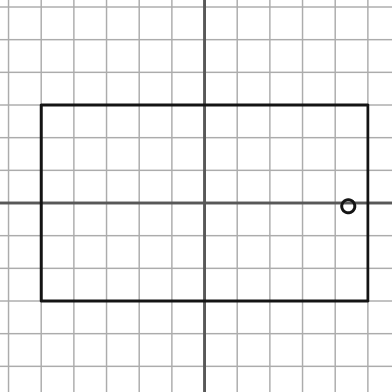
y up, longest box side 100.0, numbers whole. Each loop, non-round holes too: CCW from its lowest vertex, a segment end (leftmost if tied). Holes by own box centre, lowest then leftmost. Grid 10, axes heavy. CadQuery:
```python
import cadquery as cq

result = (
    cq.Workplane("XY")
    .moveTo(-50.0, -30.0)
    .lineTo(50.0, -30.0)
    .lineTo(50.0, 30.0)
    .lineTo(-50.0, 30.0)
    .close()
    .moveTo(44.0, -1.0)
    .circle(2.0)
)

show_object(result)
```